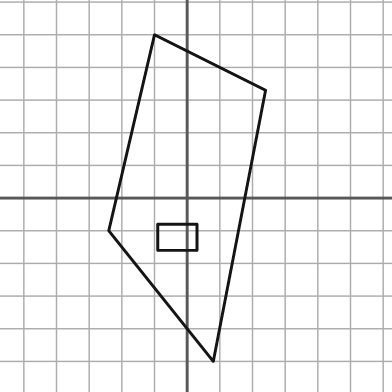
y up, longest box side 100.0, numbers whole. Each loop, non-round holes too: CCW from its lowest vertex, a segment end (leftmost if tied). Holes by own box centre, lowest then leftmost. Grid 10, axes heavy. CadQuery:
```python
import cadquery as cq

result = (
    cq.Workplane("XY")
    .moveTo(8.0, -50.0)
    .lineTo(24.0, 33.0)
    .lineTo(-10.0, 50.0)
    .lineTo(-24.0, -10.0)
    .close()
    .moveTo(-9.0, -16.0)
    .lineTo(3.0, -16.0)
    .lineTo(3.0, -8.0)
    .lineTo(-9.0, -8.0)
    .close()
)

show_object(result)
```